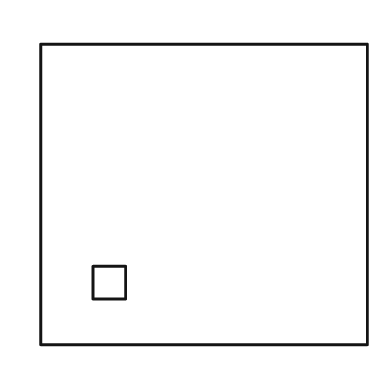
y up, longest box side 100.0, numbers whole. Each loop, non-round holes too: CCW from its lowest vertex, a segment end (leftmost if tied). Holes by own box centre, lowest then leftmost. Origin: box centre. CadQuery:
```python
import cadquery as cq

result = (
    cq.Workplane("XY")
    .moveTo(-50.0, -46.0)
    .lineTo(50.0, -46.0)
    .lineTo(50.0, 46.0)
    .lineTo(-50.0, 46.0)
    .close()
    .moveTo(-34.0, -32.0)
    .lineTo(-24.0, -32.0)
    .lineTo(-24.0, -22.0)
    .lineTo(-34.0, -22.0)
    .close()
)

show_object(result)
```